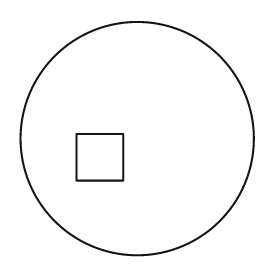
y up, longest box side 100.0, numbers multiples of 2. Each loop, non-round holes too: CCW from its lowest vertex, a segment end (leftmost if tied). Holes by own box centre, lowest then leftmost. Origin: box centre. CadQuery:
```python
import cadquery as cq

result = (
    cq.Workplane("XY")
    .moveTo(0.0, 0.0)
    .circle(50.0)
    .moveTo(-26.0, -18.0)
    .lineTo(-6.0, -18.0)
    .lineTo(-6.0, 2.0)
    .lineTo(-26.0, 2.0)
    .close()
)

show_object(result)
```